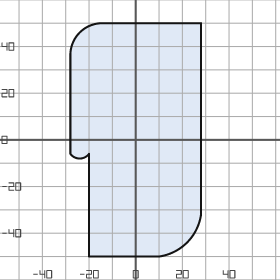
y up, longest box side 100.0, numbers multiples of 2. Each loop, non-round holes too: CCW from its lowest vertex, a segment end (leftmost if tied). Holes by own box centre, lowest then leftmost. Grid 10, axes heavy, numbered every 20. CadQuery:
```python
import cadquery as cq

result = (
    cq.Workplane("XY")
    .moveTo(-20.0, -50.0)
    .lineTo(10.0, -50.0)
    .threePointArc((22.0, -44.0), (28.0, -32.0))
    .lineTo(28.0, 50.0)
    .lineTo(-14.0, 50.0)
    .threePointArc((-24.0, 46.0), (-28.0, 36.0))
    .lineTo(-28.0, -6.0)
    .threePointArc((-24.0, -8.0), (-20.0, -6.0))
    .close()
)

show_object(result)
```